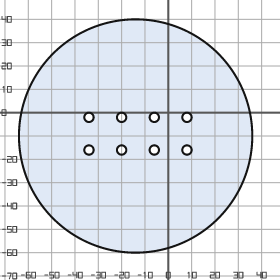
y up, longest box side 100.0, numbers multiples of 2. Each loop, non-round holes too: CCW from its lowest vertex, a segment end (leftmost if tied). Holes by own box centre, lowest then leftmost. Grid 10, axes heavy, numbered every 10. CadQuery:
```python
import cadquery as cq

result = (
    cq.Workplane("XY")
    .moveTo(-14.0, -10.0)
    .circle(50.0)
    .moveTo(-34.0, -16.0)
    .circle(2.0)
    .moveTo(-20.0, -16.0)
    .circle(2.0)
    .moveTo(-6.0, -16.0)
    .circle(2.0)
    .moveTo(8.0, -16.0)
    .circle(2.0)
    .moveTo(-34.0, -2.0)
    .circle(2.0)
    .moveTo(-20.0, -2.0)
    .circle(2.0)
    .moveTo(-6.0, -2.0)
    .circle(2.0)
    .moveTo(8.0, -2.0)
    .circle(2.0)
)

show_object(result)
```